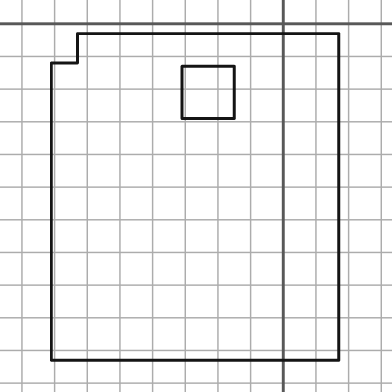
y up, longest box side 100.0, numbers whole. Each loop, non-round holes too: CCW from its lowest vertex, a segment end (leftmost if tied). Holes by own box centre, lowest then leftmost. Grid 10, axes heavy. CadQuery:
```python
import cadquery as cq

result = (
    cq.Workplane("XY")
    .moveTo(-71.0, -103.0)
    .lineTo(17.0, -103.0)
    .lineTo(17.0, -3.0)
    .lineTo(-63.0, -3.0)
    .lineTo(-63.0, -12.0)
    .lineTo(-71.0, -12.0)
    .close()
    .moveTo(-31.0, -29.0)
    .lineTo(-15.0, -29.0)
    .lineTo(-15.0, -13.0)
    .lineTo(-31.0, -13.0)
    .close()
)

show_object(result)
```